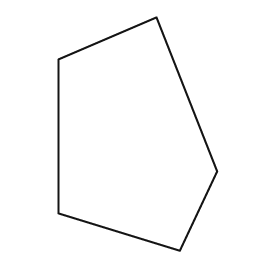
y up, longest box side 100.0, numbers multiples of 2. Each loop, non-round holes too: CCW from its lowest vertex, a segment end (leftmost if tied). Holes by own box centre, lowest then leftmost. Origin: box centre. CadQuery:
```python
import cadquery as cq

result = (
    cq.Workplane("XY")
    .moveTo(18.0, -50.0)
    .lineTo(34.0, -16.0)
    .lineTo(8.0, 50.0)
    .lineTo(-34.0, 32.0)
    .lineTo(-34.0, -34.0)
    .close()
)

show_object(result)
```